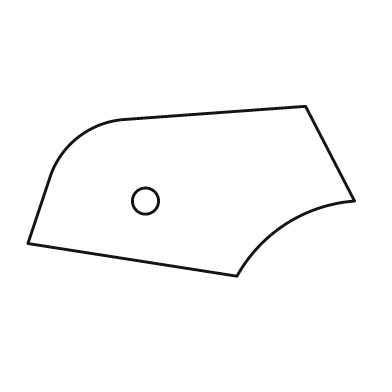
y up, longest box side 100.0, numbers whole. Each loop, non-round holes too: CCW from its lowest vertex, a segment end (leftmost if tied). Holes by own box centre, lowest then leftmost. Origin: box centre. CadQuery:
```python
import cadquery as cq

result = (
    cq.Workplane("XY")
    .moveTo(14.0, -26.0)
    .threePointArc((29.0, -10.0), (50.0, -3.0))
    .lineTo(35.0, 26.0)
    .lineTo(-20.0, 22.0)
    .threePointArc((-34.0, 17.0), (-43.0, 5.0))
    .lineTo(-50.0, -16.0)
    .close()
    .moveTo(-14.0, -3.0)
    .circle(4.0)
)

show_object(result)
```